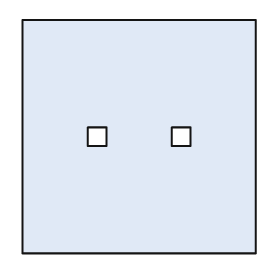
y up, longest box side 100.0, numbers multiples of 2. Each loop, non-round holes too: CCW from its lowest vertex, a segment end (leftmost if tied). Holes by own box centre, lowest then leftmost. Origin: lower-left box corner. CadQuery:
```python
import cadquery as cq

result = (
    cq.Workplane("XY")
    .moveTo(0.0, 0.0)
    .lineTo(100.0, 0.0)
    .lineTo(100.0, 100.0)
    .lineTo(0.0, 100.0)
    .close()
    .moveTo(28.0, 46.0)
    .lineTo(36.0, 46.0)
    .lineTo(36.0, 54.0)
    .lineTo(28.0, 54.0)
    .close()
    .moveTo(64.0, 46.0)
    .lineTo(72.0, 46.0)
    .lineTo(72.0, 54.0)
    .lineTo(64.0, 54.0)
    .close()
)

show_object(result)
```